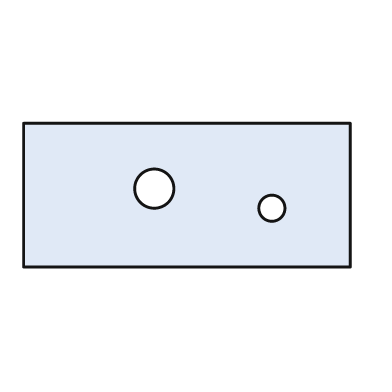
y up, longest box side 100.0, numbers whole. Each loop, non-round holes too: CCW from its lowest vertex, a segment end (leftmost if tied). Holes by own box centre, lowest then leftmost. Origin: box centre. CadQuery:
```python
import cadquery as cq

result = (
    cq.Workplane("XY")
    .moveTo(-50.0, -22.0)
    .lineTo(50.0, -22.0)
    .lineTo(50.0, 22.0)
    .lineTo(-50.0, 22.0)
    .close()
    .moveTo(26.0, -4.0)
    .circle(4.0)
    .moveTo(-10.0, 2.0)
    .circle(6.0)
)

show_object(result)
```